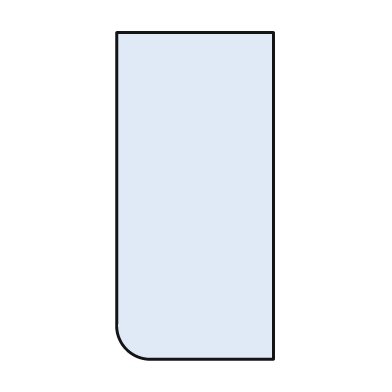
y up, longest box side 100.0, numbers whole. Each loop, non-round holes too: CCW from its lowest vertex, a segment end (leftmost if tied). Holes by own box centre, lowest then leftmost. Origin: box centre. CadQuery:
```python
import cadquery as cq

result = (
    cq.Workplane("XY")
    .moveTo(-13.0, -50.0)
    .lineTo(24.0, -50.0)
    .lineTo(24.0, 50.0)
    .lineTo(-24.0, 50.0)
    .lineTo(-24.0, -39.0)
    .threePointArc((-21.0, -47.0), (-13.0, -50.0))
    .close()
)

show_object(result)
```